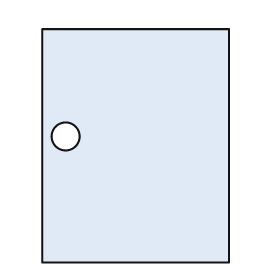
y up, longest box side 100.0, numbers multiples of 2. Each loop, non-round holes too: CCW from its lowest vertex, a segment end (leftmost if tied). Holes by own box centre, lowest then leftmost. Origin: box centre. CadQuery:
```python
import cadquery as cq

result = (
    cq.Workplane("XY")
    .moveTo(-40.0, -50.0)
    .lineTo(40.0, -50.0)
    .lineTo(40.0, 50.0)
    .lineTo(-40.0, 50.0)
    .close()
    .moveTo(-30.0, 4.0)
    .circle(6.0)
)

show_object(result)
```